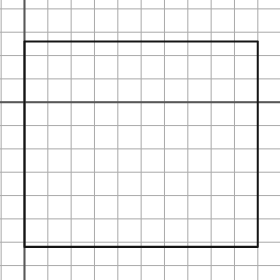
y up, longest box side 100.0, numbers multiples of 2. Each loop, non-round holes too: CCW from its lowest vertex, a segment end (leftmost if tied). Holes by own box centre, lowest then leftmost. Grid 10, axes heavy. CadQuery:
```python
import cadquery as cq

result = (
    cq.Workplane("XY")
    .moveTo(0.0, -62.0)
    .lineTo(100.0, -62.0)
    .lineTo(100.0, 26.0)
    .lineTo(0.0, 26.0)
    .close()
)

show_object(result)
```